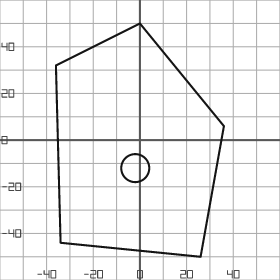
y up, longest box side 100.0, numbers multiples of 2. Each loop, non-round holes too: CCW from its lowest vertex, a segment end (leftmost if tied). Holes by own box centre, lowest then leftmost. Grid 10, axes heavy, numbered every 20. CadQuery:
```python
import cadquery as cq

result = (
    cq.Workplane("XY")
    .moveTo(26.0, -50.0)
    .lineTo(36.0, 6.0)
    .lineTo(0.0, 50.0)
    .lineTo(-36.0, 32.0)
    .lineTo(-34.0, -44.0)
    .close()
    .moveTo(-2.0, -12.0)
    .circle(6.0)
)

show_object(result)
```